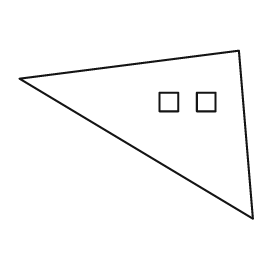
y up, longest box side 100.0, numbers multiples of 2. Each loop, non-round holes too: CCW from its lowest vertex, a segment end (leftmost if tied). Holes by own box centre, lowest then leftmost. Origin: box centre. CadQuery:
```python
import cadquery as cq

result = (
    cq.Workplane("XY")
    .moveTo(50.0, -36.0)
    .lineTo(44.0, 36.0)
    .lineTo(-50.0, 24.0)
    .close()
    .moveTo(10.0, 10.0)
    .lineTo(18.0, 10.0)
    .lineTo(18.0, 18.0)
    .lineTo(10.0, 18.0)
    .close()
    .moveTo(26.0, 10.0)
    .lineTo(34.0, 10.0)
    .lineTo(34.0, 18.0)
    .lineTo(26.0, 18.0)
    .close()
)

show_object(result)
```